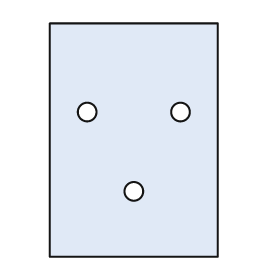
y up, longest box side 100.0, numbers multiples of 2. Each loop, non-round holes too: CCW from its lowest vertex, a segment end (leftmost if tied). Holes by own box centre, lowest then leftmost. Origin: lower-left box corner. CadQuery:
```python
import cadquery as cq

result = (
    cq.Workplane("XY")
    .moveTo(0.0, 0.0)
    .lineTo(72.0, 0.0)
    .lineTo(72.0, 100.0)
    .lineTo(0.0, 100.0)
    .close()
    .moveTo(36.0, 28.0)
    .circle(4.0)
    .moveTo(16.0, 62.0)
    .circle(4.0)
    .moveTo(56.0, 62.0)
    .circle(4.0)
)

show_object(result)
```